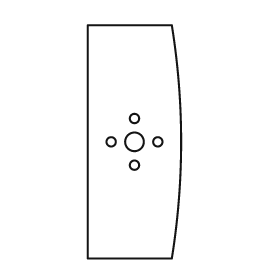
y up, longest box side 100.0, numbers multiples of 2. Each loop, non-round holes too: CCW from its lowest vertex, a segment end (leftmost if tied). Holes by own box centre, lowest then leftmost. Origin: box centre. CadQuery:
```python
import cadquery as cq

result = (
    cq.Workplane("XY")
    .moveTo(-20.0, -50.0)
    .lineTo(16.0, -50.0)
    .threePointArc((20.0, 0.0), (16.0, 50.0))
    .lineTo(-20.0, 50.0)
    .close()
    .moveTo(0.0, -10.0)
    .circle(2.0)
    .moveTo(-10.0, 0.0)
    .circle(2.0)
    .moveTo(0.0, 0.0)
    .circle(4.0)
    .moveTo(10.0, 0.0)
    .circle(2.0)
    .moveTo(0.0, 10.0)
    .circle(2.0)
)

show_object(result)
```